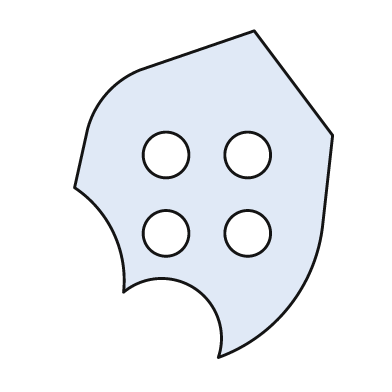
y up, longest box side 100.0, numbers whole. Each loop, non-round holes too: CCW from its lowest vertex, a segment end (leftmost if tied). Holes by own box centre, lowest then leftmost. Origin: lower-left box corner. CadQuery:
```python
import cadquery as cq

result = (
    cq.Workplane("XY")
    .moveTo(44.0, 0.0)
    .threePointArc((66.0, 16.0), (76.0, 41.0))
    .lineTo(79.0, 68.0)
    .lineTo(55.0, 100.0)
    .lineTo(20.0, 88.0)
    .threePointArc((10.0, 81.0), (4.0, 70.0))
    .lineTo(0.0, 52.0)
    .threePointArc((12.0, 38.0), (15.0, 20.0))
    .threePointArc((37.0, 21.0), (44.0, 0.0))
    .close()
    .moveTo(28.0, 38.0)
    .circle(7.0)
    .moveTo(53.0, 38.0)
    .circle(7.0)
    .moveTo(28.0, 62.0)
    .circle(7.0)
    .moveTo(53.0, 62.0)
    .circle(7.0)
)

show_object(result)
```